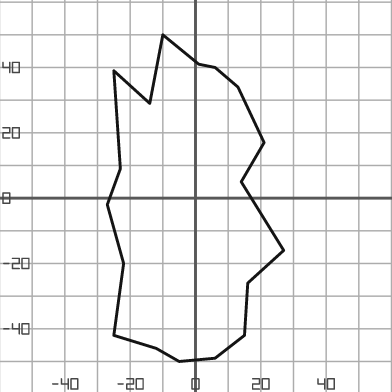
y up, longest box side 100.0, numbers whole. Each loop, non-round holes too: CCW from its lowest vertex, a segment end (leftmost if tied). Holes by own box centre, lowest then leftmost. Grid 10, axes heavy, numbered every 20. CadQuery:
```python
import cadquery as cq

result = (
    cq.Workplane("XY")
    .moveTo(-5.0, -50.0)
    .lineTo(6.0, -49.0)
    .lineTo(15.0, -42.0)
    .lineTo(16.0, -26.0)
    .lineTo(27.0, -16.0)
    .lineTo(14.0, 5.0)
    .lineTo(21.0, 17.0)
    .lineTo(13.0, 34.0)
    .lineTo(6.0, 40.0)
    .lineTo(1.0, 41.0)
    .lineTo(-10.0, 50.0)
    .lineTo(-14.0, 29.0)
    .lineTo(-25.0, 39.0)
    .lineTo(-23.0, 9.0)
    .lineTo(-27.0, -2.0)
    .lineTo(-22.0, -20.0)
    .lineTo(-25.0, -42.0)
    .lineTo(-12.0, -46.0)
    .close()
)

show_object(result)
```